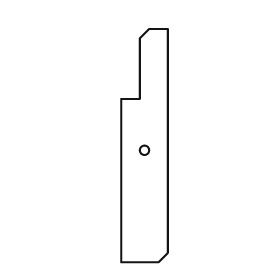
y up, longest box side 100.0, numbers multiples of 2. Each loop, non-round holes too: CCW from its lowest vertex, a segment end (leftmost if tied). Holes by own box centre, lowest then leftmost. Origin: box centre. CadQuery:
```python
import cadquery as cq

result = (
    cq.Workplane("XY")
    .moveTo(-10.0, -50.0)
    .lineTo(6.0, -50.0)
    .lineTo(10.0, -46.0)
    .lineTo(10.0, 50.0)
    .lineTo(2.0, 50.0)
    .lineTo(-2.0, 46.0)
    .lineTo(-2.0, 20.0)
    .lineTo(-10.0, 20.0)
    .close()
    .moveTo(0.0, -2.0)
    .circle(2.0)
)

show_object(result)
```